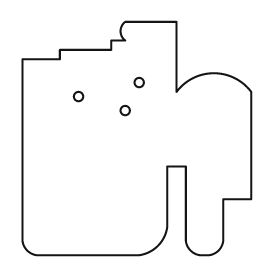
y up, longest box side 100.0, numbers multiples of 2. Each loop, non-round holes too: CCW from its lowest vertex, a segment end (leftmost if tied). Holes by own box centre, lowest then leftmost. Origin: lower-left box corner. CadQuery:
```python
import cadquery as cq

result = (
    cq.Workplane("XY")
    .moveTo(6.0, 0.0)
    .lineTo(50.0, 0.0)
    .threePointArc((58.0, 4.0), (62.0, 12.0))
    .lineTo(62.0, 38.0)
    .lineTo(70.0, 38.0)
    .lineTo(70.0, 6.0)
    .threePointArc((72.0, 2.0), (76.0, 0.0))
    .lineTo(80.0, 0.0)
    .threePointArc((84.0, 2.0), (86.0, 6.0))
    .lineTo(86.0, 24.0)
    .lineTo(98.0, 24.0)
    .lineTo(98.0, 70.0)
    .threePointArc((82.0, 78.0), (66.0, 70.0))
    .lineTo(66.0, 100.0)
    .lineTo(44.0, 100.0)
    .threePointArc((42.0, 96.0), (44.0, 92.0))
    .lineTo(38.0, 92.0)
    .lineTo(38.0, 88.0)
    .lineTo(16.0, 88.0)
    .lineTo(16.0, 84.0)
    .lineTo(0.0, 84.0)
    .lineTo(0.0, 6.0)
    .threePointArc((2.0, 2.0), (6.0, 0.0))
    .close()
    .moveTo(44.0, 62.0)
    .circle(2.0)
    .moveTo(24.0, 68.0)
    .circle(2.0)
    .moveTo(50.0, 74.0)
    .circle(2.0)
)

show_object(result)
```